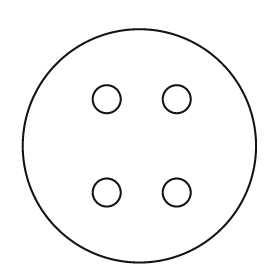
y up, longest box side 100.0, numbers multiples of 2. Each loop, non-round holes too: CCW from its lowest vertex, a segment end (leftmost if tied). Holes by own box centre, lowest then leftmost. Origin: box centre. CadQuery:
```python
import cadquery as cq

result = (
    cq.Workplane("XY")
    .moveTo(0.0, 0.0)
    .circle(50.0)
    .moveTo(-14.0, -20.0)
    .circle(6.0)
    .moveTo(16.0, -20.0)
    .circle(6.0)
    .moveTo(-14.0, 20.0)
    .circle(6.0)
    .moveTo(16.0, 20.0)
    .circle(6.0)
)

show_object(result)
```